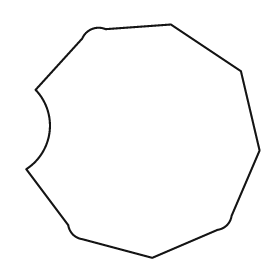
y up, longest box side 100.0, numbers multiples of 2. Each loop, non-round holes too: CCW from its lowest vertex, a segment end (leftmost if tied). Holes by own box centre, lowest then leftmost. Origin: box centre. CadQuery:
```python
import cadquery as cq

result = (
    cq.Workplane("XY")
    .moveTo(4.0, -50.0)
    .lineTo(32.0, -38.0)
    .threePointArc((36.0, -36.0), (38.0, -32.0))
    .lineTo(50.0, -4.0)
    .lineTo(42.0, 30.0)
    .lineTo(12.0, 50.0)
    .lineTo(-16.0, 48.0)
    .threePointArc((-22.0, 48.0), (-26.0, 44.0))
    .lineTo(-46.0, 22.0)
    .threePointArc((-40.0, 4.0), (-50.0, -12.0))
    .lineTo(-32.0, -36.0)
    .threePointArc((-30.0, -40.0), (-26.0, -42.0))
    .close()
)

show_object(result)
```